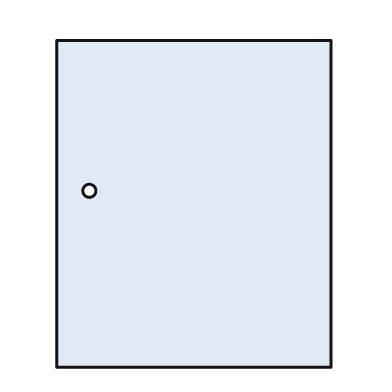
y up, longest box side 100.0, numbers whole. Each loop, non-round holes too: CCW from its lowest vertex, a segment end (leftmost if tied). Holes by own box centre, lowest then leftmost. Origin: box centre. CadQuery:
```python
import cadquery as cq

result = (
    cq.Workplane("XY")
    .moveTo(-42.0, -50.0)
    .lineTo(42.0, -50.0)
    .lineTo(42.0, 50.0)
    .lineTo(-42.0, 50.0)
    .close()
    .moveTo(-32.0, 4.0)
    .circle(2.0)
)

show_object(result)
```